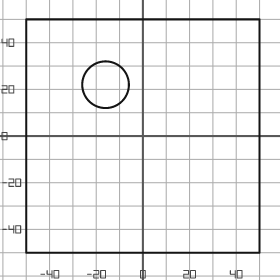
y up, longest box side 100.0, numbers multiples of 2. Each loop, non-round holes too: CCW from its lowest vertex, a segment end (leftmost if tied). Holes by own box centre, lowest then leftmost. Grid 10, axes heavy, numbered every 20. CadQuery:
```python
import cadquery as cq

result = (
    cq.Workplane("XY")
    .moveTo(-50.0, -50.0)
    .lineTo(50.0, -50.0)
    .lineTo(50.0, 50.0)
    .lineTo(-50.0, 50.0)
    .close()
    .moveTo(-16.0, 22.0)
    .circle(10.0)
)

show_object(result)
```